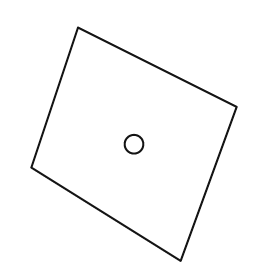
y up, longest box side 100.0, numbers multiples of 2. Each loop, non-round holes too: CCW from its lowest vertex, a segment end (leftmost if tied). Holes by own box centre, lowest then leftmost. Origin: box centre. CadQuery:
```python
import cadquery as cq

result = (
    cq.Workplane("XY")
    .moveTo(20.0, -50.0)
    .lineTo(44.0, 16.0)
    .lineTo(-24.0, 50.0)
    .lineTo(-44.0, -10.0)
    .close()
    .moveTo(0.0, 0.0)
    .circle(4.0)
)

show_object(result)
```